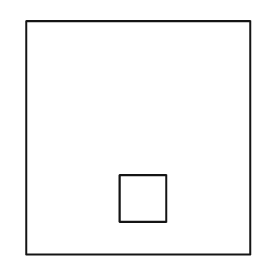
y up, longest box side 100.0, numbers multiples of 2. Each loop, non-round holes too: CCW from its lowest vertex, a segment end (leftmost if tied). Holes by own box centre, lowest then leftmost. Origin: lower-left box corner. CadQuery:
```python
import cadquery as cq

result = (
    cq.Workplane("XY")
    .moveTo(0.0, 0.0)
    .lineTo(96.0, 0.0)
    .lineTo(96.0, 100.0)
    .lineTo(0.0, 100.0)
    .close()
    .moveTo(40.0, 14.0)
    .lineTo(60.0, 14.0)
    .lineTo(60.0, 34.0)
    .lineTo(40.0, 34.0)
    .close()
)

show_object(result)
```